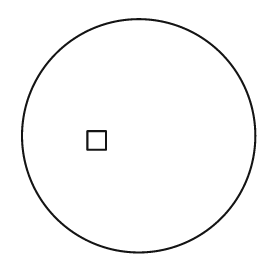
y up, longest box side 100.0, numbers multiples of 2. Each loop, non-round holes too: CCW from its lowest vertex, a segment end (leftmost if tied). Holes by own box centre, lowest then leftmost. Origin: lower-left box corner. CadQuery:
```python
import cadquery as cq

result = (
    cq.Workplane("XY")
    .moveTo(50.0, 50.0)
    .circle(50.0)
    .moveTo(28.0, 44.0)
    .lineTo(36.0, 44.0)
    .lineTo(36.0, 52.0)
    .lineTo(28.0, 52.0)
    .close()
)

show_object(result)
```